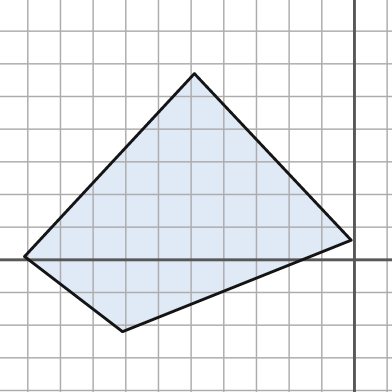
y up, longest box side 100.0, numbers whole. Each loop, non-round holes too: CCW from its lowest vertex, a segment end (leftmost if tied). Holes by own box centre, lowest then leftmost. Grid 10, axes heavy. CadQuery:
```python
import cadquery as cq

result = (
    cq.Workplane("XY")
    .moveTo(-71.0, -22.0)
    .lineTo(-1.0, 6.0)
    .lineTo(-49.0, 57.0)
    .lineTo(-101.0, 1.0)
    .close()
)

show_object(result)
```